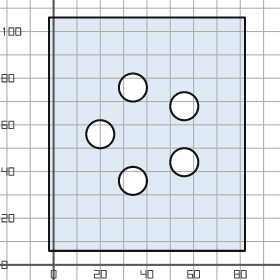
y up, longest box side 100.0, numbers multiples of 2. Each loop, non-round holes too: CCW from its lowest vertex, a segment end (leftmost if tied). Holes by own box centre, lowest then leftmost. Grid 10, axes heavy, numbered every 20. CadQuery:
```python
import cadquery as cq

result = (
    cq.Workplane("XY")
    .moveTo(-2.0, 6.0)
    .lineTo(82.0, 6.0)
    .lineTo(82.0, 106.0)
    .lineTo(-2.0, 106.0)
    .close()
    .moveTo(34.0, 36.0)
    .circle(6.0)
    .moveTo(56.0, 44.0)
    .circle(6.0)
    .moveTo(20.0, 56.0)
    .circle(6.0)
    .moveTo(56.0, 68.0)
    .circle(6.0)
    .moveTo(34.0, 76.0)
    .circle(6.0)
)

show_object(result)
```